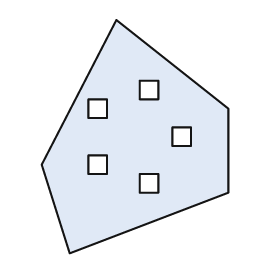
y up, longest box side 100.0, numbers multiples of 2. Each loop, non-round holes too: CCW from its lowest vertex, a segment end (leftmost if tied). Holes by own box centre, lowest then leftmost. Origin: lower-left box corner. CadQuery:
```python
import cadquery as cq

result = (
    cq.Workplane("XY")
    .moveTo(12.0, 0.0)
    .lineTo(80.0, 26.0)
    .lineTo(80.0, 62.0)
    .lineTo(32.0, 100.0)
    .lineTo(0.0, 38.0)
    .close()
    .moveTo(42.0, 26.0)
    .lineTo(50.0, 26.0)
    .lineTo(50.0, 34.0)
    .lineTo(42.0, 34.0)
    .close()
    .moveTo(20.0, 34.0)
    .lineTo(28.0, 34.0)
    .lineTo(28.0, 42.0)
    .lineTo(20.0, 42.0)
    .close()
    .moveTo(56.0, 46.0)
    .lineTo(64.0, 46.0)
    .lineTo(64.0, 54.0)
    .lineTo(56.0, 54.0)
    .close()
    .moveTo(20.0, 58.0)
    .lineTo(28.0, 58.0)
    .lineTo(28.0, 66.0)
    .lineTo(20.0, 66.0)
    .close()
    .moveTo(42.0, 66.0)
    .lineTo(50.0, 66.0)
    .lineTo(50.0, 74.0)
    .lineTo(42.0, 74.0)
    .close()
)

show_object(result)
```